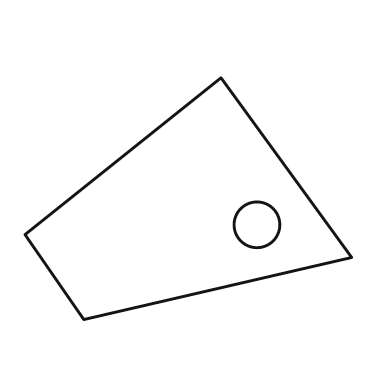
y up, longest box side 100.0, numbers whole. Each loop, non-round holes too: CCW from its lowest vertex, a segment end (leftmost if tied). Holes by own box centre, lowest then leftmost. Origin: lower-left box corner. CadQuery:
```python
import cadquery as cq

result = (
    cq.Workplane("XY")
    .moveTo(18.0, 0.0)
    .lineTo(100.0, 19.0)
    .lineTo(60.0, 74.0)
    .lineTo(0.0, 26.0)
    .close()
    .moveTo(71.0, 29.0)
    .circle(7.0)
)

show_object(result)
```